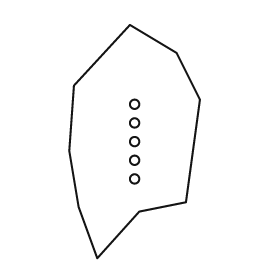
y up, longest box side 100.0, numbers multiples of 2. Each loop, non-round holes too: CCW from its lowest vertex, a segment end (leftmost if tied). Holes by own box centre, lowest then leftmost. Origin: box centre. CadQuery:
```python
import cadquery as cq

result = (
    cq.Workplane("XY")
    .moveTo(-16.0, -50.0)
    .lineTo(2.0, -30.0)
    .lineTo(22.0, -26.0)
    .lineTo(28.0, 18.0)
    .lineTo(18.0, 38.0)
    .lineTo(-2.0, 50.0)
    .lineTo(-26.0, 24.0)
    .lineTo(-28.0, -4.0)
    .lineTo(-24.0, -28.0)
    .close()
    .moveTo(0.0, -16.0)
    .circle(2.0)
    .moveTo(0.0, -8.0)
    .circle(2.0)
    .moveTo(0.0, 0.0)
    .circle(2.0)
    .moveTo(0.0, 8.0)
    .circle(2.0)
    .moveTo(0.0, 16.0)
    .circle(2.0)
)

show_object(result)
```